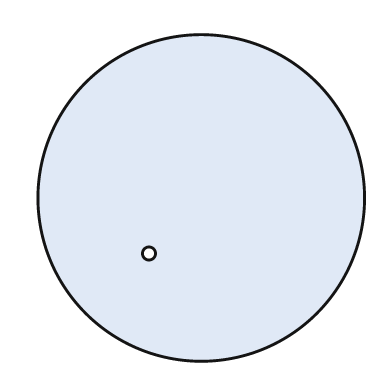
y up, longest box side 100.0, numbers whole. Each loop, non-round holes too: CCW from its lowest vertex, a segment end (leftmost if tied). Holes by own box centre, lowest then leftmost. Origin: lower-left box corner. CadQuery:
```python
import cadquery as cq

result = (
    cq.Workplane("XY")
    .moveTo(50.0, 50.0)
    .circle(50.0)
    .moveTo(34.0, 33.0)
    .circle(2.0)
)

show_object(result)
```